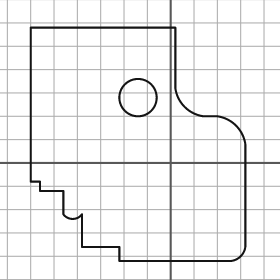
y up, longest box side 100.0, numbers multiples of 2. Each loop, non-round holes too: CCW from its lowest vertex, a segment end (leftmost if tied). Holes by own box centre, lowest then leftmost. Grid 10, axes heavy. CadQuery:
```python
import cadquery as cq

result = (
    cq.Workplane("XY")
    .moveTo(-22.0, -42.0)
    .lineTo(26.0, -42.0)
    .threePointArc((30.0, -40.0), (32.0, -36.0))
    .lineTo(32.0, 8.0)
    .threePointArc((28.0, 16.0), (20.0, 20.0))
    .lineTo(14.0, 20.0)
    .threePointArc((6.0, 24.0), (2.0, 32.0))
    .lineTo(2.0, 58.0)
    .lineTo(-60.0, 58.0)
    .lineTo(-60.0, -8.0)
    .lineTo(-56.0, -8.0)
    .lineTo(-56.0, -12.0)
    .lineTo(-46.0, -12.0)
    .lineTo(-46.0, -22.0)
    .threePointArc((-42.0, -24.0), (-38.0, -22.0))
    .lineTo(-38.0, -36.0)
    .lineTo(-22.0, -36.0)
    .close()
    .moveTo(-14.0, 28.0)
    .circle(8.0)
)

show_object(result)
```